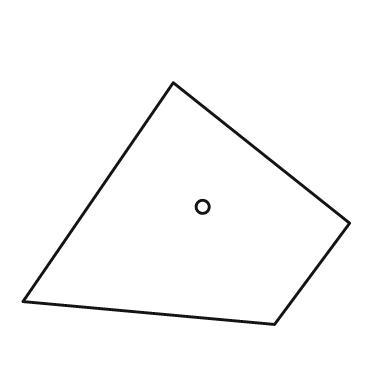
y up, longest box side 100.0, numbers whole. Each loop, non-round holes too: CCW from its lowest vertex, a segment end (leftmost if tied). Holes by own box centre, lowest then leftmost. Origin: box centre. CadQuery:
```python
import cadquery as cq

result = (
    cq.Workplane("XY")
    .moveTo(27.0, -37.0)
    .lineTo(50.0, -6.0)
    .lineTo(-4.0, 37.0)
    .lineTo(-50.0, -30.0)
    .close()
    .moveTo(5.0, -1.0)
    .circle(2.0)
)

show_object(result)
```